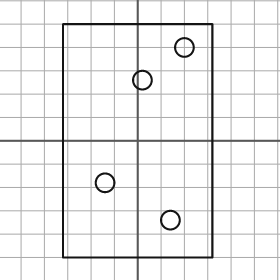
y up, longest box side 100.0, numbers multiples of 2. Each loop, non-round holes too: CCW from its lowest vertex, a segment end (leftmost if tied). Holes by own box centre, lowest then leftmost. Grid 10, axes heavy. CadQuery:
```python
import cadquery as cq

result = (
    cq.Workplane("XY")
    .moveTo(-32.0, -50.0)
    .lineTo(32.0, -50.0)
    .lineTo(32.0, 50.0)
    .lineTo(-32.0, 50.0)
    .close()
    .moveTo(14.0, -34.0)
    .circle(4.0)
    .moveTo(-14.0, -18.0)
    .circle(4.0)
    .moveTo(2.0, 26.0)
    .circle(4.0)
    .moveTo(20.0, 40.0)
    .circle(4.0)
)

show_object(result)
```